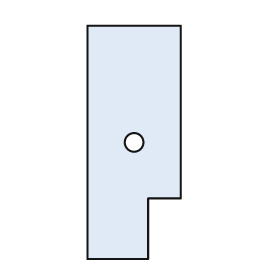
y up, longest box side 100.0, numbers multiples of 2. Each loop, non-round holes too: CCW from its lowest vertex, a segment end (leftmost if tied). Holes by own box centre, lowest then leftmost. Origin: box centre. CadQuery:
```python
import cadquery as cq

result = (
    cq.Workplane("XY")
    .moveTo(-20.0, -50.0)
    .lineTo(6.0, -50.0)
    .lineTo(6.0, -24.0)
    .lineTo(20.0, -24.0)
    .lineTo(20.0, 50.0)
    .lineTo(-20.0, 50.0)
    .close()
    .moveTo(0.0, 0.0)
    .circle(4.0)
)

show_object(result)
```